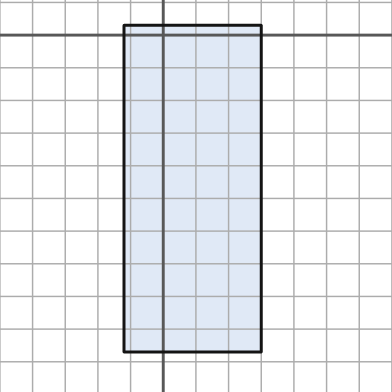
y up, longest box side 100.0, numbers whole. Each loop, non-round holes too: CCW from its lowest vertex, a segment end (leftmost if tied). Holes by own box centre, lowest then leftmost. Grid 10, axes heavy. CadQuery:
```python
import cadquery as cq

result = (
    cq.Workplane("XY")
    .moveTo(-12.0, -97.0)
    .lineTo(30.0, -97.0)
    .lineTo(30.0, 3.0)
    .lineTo(-12.0, 3.0)
    .close()
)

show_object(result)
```